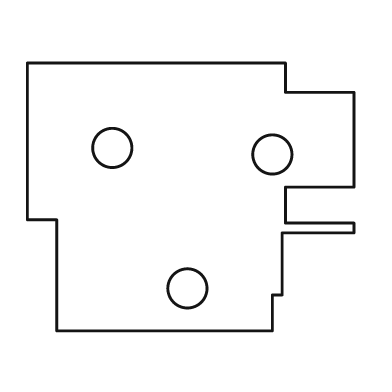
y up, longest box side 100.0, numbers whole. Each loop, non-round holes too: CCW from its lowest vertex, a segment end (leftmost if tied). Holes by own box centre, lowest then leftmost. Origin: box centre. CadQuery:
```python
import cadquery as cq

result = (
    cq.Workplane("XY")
    .moveTo(-41.0, -41.0)
    .lineTo(25.0, -41.0)
    .lineTo(25.0, -30.0)
    .lineTo(28.0, -30.0)
    .lineTo(28.0, -11.0)
    .lineTo(50.0, -11.0)
    .lineTo(50.0, -8.0)
    .lineTo(29.0, -8.0)
    .lineTo(29.0, 3.0)
    .lineTo(50.0, 3.0)
    .lineTo(50.0, 32.0)
    .lineTo(29.0, 32.0)
    .lineTo(29.0, 41.0)
    .lineTo(-50.0, 41.0)
    .lineTo(-50.0, -7.0)
    .lineTo(-41.0, -7.0)
    .close()
    .moveTo(-1.0, -28.0)
    .circle(6.0)
    .moveTo(25.0, 13.0)
    .circle(6.0)
    .moveTo(-24.0, 15.0)
    .circle(6.0)
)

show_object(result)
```